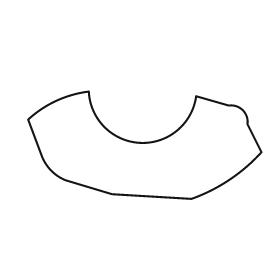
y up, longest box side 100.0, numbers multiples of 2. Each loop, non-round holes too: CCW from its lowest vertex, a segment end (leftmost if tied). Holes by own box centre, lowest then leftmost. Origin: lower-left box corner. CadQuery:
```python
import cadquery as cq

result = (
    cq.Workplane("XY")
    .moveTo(70.0, 0.0)
    .threePointArc((86.0, 8.0), (100.0, 20.0))
    .lineTo(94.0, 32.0)
    .threePointArc((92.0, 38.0), (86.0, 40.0))
    .lineTo(72.0, 44.0)
    .threePointArc((48.0, 24.0), (26.0, 46.0))
    .threePointArc((12.0, 42.0), (0.0, 34.0))
    .lineTo(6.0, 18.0)
    .threePointArc((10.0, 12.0), (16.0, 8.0))
    .lineTo(36.0, 2.0)
    .close()
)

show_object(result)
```